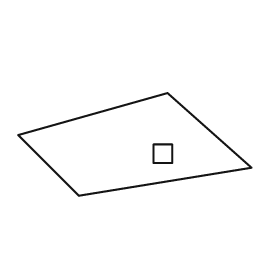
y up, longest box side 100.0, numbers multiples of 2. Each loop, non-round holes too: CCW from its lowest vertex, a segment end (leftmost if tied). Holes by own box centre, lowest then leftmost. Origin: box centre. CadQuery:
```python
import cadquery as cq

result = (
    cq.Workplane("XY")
    .moveTo(-24.0, -22.0)
    .lineTo(50.0, -10.0)
    .lineTo(14.0, 22.0)
    .lineTo(-50.0, 4.0)
    .close()
    .moveTo(8.0, -8.0)
    .lineTo(16.0, -8.0)
    .lineTo(16.0, 0.0)
    .lineTo(8.0, 0.0)
    .close()
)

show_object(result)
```